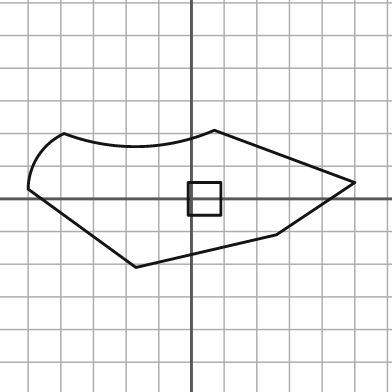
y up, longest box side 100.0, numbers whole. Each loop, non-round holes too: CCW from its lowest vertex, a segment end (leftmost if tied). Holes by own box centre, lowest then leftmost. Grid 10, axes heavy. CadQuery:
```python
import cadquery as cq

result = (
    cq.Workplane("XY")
    .moveTo(-17.0, -21.0)
    .lineTo(26.0, -11.0)
    .lineTo(50.0, 5.0)
    .lineTo(7.0, 21.0)
    .threePointArc((-16.0, 16.0), (-39.0, 20.0))
    .threePointArc((-47.0, 13.0), (-50.0, 3.0))
    .close()
    .moveTo(-1.0, -5.0)
    .lineTo(9.0, -5.0)
    .lineTo(9.0, 5.0)
    .lineTo(-1.0, 5.0)
    .close()
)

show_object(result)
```